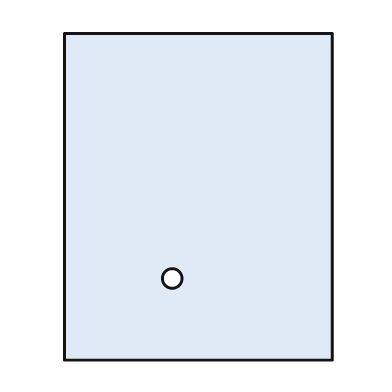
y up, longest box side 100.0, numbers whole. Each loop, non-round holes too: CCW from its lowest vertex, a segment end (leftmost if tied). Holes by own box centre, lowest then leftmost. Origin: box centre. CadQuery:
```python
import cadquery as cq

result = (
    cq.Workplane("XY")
    .moveTo(-41.0, -50.0)
    .lineTo(41.0, -50.0)
    .lineTo(41.0, 50.0)
    .lineTo(-41.0, 50.0)
    .close()
    .moveTo(-8.0, -25.0)
    .circle(3.0)
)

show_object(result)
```